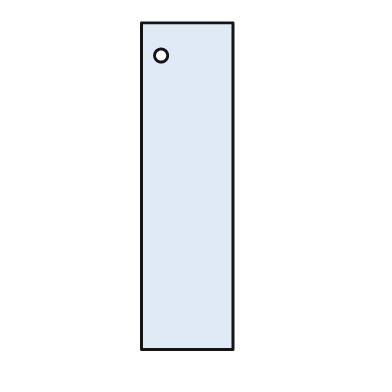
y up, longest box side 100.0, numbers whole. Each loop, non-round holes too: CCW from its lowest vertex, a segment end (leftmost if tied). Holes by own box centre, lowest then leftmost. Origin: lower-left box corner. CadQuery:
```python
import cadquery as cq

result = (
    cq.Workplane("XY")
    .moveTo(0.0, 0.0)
    .lineTo(28.0, 0.0)
    .lineTo(28.0, 100.0)
    .lineTo(0.0, 100.0)
    .close()
    .moveTo(6.0, 90.0)
    .circle(2.0)
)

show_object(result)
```